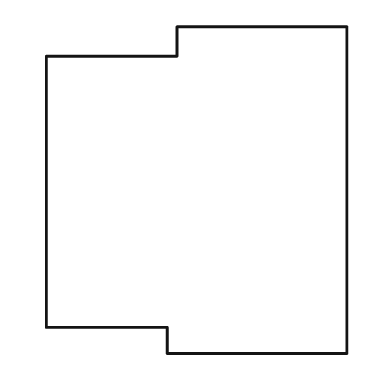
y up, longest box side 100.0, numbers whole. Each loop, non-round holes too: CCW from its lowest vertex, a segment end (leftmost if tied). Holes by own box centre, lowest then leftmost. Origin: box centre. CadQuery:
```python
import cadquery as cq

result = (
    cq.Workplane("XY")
    .moveTo(-9.0, -50.0)
    .lineTo(46.0, -50.0)
    .lineTo(46.0, 50.0)
    .lineTo(-6.0, 50.0)
    .lineTo(-6.0, 41.0)
    .lineTo(-46.0, 41.0)
    .lineTo(-46.0, -42.0)
    .lineTo(-9.0, -42.0)
    .close()
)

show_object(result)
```